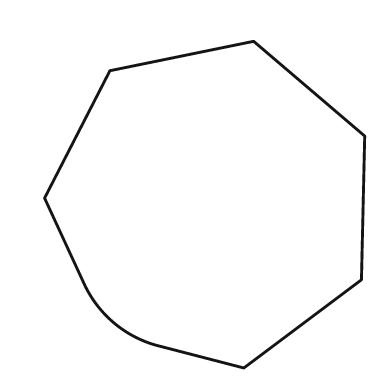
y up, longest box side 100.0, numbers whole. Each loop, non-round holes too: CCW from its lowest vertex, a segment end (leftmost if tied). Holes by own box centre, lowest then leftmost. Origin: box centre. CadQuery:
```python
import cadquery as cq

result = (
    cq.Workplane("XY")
    .moveTo(12.0, -50.0)
    .lineTo(48.0, -23.0)
    .lineTo(49.0, 21.0)
    .lineTo(15.0, 50.0)
    .lineTo(-29.0, 41.0)
    .lineTo(-49.0, 2.0)
    .lineTo(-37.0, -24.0)
    .threePointArc((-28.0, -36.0), (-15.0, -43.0))
    .close()
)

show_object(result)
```